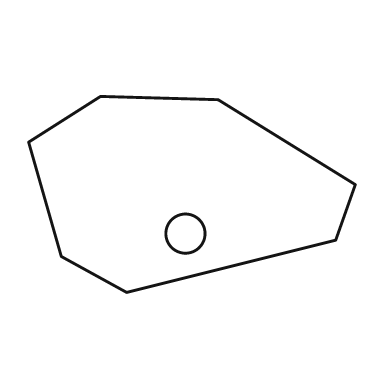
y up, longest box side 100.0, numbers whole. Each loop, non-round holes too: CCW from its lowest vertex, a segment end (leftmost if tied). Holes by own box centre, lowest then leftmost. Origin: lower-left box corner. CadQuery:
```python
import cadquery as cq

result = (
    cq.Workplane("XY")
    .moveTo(30.0, 0.0)
    .lineTo(94.0, 16.0)
    .lineTo(100.0, 33.0)
    .lineTo(58.0, 59.0)
    .lineTo(22.0, 60.0)
    .lineTo(0.0, 46.0)
    .lineTo(10.0, 11.0)
    .close()
    .moveTo(48.0, 18.0)
    .circle(6.0)
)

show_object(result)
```